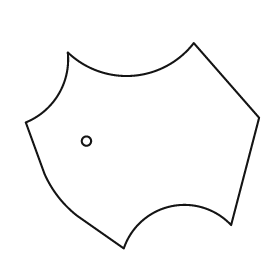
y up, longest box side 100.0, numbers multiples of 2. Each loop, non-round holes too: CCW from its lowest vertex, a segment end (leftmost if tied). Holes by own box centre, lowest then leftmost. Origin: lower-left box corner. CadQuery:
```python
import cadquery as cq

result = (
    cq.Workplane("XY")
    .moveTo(42.0, 0.0)
    .threePointArc((62.0, 18.0), (88.0, 10.0))
    .lineTo(100.0, 56.0)
    .lineTo(72.0, 88.0)
    .threePointArc((46.0, 74.0), (18.0, 84.0))
    .threePointArc((14.0, 66.0), (0.0, 54.0))
    .lineTo(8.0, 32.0)
    .threePointArc((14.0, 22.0), (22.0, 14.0))
    .close()
    .moveTo(26.0, 46.0)
    .circle(2.0)
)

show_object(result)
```